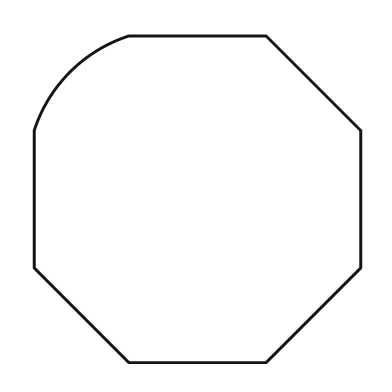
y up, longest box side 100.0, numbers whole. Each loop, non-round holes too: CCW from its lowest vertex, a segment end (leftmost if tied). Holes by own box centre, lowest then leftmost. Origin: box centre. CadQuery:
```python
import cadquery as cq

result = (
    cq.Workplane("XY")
    .moveTo(-21.0, -50.0)
    .lineTo(21.0, -50.0)
    .lineTo(50.0, -21.0)
    .lineTo(50.0, 21.0)
    .lineTo(21.0, 50.0)
    .lineTo(-21.0, 50.0)
    .threePointArc((-39.0, 39.0), (-50.0, 21.0))
    .lineTo(-50.0, -21.0)
    .close()
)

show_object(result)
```